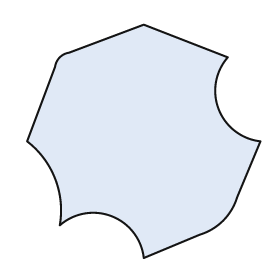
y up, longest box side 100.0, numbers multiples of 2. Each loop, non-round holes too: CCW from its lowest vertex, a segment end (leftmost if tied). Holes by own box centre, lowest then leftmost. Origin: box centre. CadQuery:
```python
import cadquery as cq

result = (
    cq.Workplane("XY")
    .moveTo(0.0, -50.0)
    .lineTo(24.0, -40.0)
    .threePointArc((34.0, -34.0), (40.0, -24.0))
    .lineTo(50.0, 0.0)
    .threePointArc((32.0, 14.0), (36.0, 36.0))
    .lineTo(0.0, 50.0)
    .lineTo(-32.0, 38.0)
    .threePointArc((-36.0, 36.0), (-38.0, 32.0))
    .lineTo(-50.0, 0.0)
    .threePointArc((-38.0, -16.0), (-36.0, -36.0))
    .threePointArc((-14.0, -32.0), (0.0, -50.0))
    .close()
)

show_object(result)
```